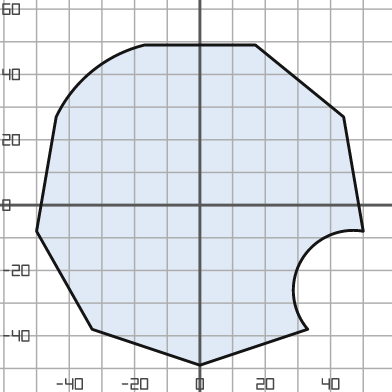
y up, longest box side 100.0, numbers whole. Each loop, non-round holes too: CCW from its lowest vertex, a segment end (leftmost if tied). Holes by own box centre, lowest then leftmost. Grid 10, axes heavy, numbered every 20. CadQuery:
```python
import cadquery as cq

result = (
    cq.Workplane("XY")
    .moveTo(0.0, -49.0)
    .lineTo(33.0, -38.0)
    .threePointArc((31.0, -17.0), (50.0, -8.0))
    .lineTo(44.0, 27.0)
    .lineTo(17.0, 49.0)
    .lineTo(-17.0, 49.0)
    .threePointArc((-33.0, 41.0), (-44.0, 27.0))
    .lineTo(-50.0, -8.0)
    .lineTo(-33.0, -38.0)
    .close()
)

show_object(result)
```